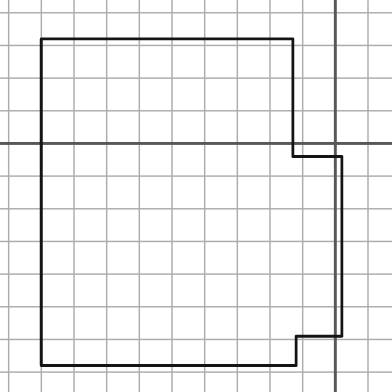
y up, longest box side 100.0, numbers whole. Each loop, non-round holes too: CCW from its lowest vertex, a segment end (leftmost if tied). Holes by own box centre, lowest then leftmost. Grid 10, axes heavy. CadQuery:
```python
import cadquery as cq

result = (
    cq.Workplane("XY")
    .moveTo(-90.0, -68.0)
    .lineTo(-12.0, -68.0)
    .lineTo(-12.0, -59.0)
    .lineTo(2.0, -59.0)
    .lineTo(2.0, -4.0)
    .lineTo(-13.0, -4.0)
    .lineTo(-13.0, 32.0)
    .lineTo(-90.0, 32.0)
    .close()
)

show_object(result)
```